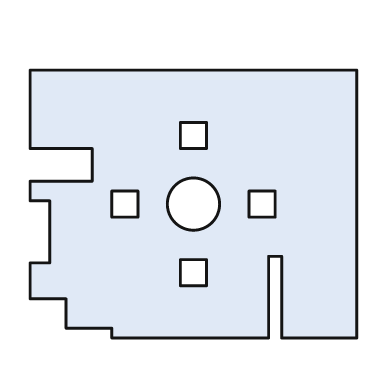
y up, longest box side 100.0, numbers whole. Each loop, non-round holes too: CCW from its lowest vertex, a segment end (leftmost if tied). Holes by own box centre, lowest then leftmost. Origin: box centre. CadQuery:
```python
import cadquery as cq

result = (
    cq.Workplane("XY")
    .moveTo(-25.0, -41.0)
    .lineTo(23.0, -41.0)
    .lineTo(23.0, -16.0)
    .lineTo(27.0, -16.0)
    .lineTo(27.0, -41.0)
    .lineTo(50.0, -41.0)
    .lineTo(50.0, 41.0)
    .lineTo(-50.0, 41.0)
    .lineTo(-50.0, 17.0)
    .lineTo(-31.0, 17.0)
    .lineTo(-31.0, 7.0)
    .lineTo(-50.0, 7.0)
    .lineTo(-50.0, 1.0)
    .lineTo(-44.0, 1.0)
    .lineTo(-44.0, -18.0)
    .lineTo(-50.0, -18.0)
    .lineTo(-50.0, -29.0)
    .lineTo(-39.0, -29.0)
    .lineTo(-39.0, -38.0)
    .lineTo(-25.0, -38.0)
    .close()
    .moveTo(-4.0, -25.0)
    .lineTo(4.0, -25.0)
    .lineTo(4.0, -17.0)
    .lineTo(-4.0, -17.0)
    .close()
    .moveTo(-25.0, -4.0)
    .lineTo(-17.0, -4.0)
    .lineTo(-17.0, 4.0)
    .lineTo(-25.0, 4.0)
    .close()
    .moveTo(0.0, 0.0)
    .circle(8.0)
    .moveTo(17.0, -4.0)
    .lineTo(25.0, -4.0)
    .lineTo(25.0, 4.0)
    .lineTo(17.0, 4.0)
    .close()
    .moveTo(-4.0, 17.0)
    .lineTo(4.0, 17.0)
    .lineTo(4.0, 25.0)
    .lineTo(-4.0, 25.0)
    .close()
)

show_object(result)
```